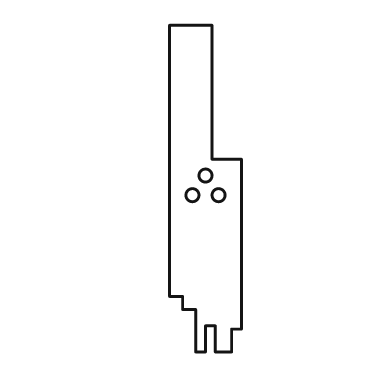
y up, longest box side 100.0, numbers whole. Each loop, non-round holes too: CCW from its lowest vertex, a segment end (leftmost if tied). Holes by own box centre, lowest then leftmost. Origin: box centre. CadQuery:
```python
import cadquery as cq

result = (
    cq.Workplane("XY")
    .moveTo(-3.0, -50.0)
    .lineTo(0.0, -50.0)
    .lineTo(0.0, -42.0)
    .lineTo(3.0, -42.0)
    .lineTo(3.0, -50.0)
    .lineTo(8.0, -50.0)
    .lineTo(8.0, -43.0)
    .lineTo(11.0, -43.0)
    .lineTo(11.0, 9.0)
    .lineTo(2.0, 9.0)
    .lineTo(2.0, 50.0)
    .lineTo(-11.0, 50.0)
    .lineTo(-11.0, -33.0)
    .lineTo(-7.0, -33.0)
    .lineTo(-7.0, -37.0)
    .lineTo(-3.0, -37.0)
    .close()
    .moveTo(-4.0, -2.0)
    .circle(2.0)
    .moveTo(4.0, -2.0)
    .circle(2.0)
    .moveTo(0.0, 4.0)
    .circle(2.0)
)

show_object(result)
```